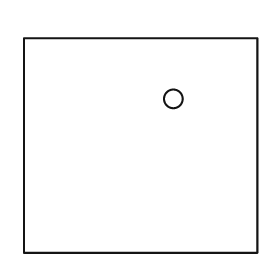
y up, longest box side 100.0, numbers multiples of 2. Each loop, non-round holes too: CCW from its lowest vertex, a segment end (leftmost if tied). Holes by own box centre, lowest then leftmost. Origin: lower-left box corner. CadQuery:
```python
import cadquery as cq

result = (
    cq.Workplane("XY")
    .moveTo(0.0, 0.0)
    .lineTo(100.0, 0.0)
    .lineTo(100.0, 92.0)
    .lineTo(0.0, 92.0)
    .close()
    .moveTo(64.0, 66.0)
    .circle(4.0)
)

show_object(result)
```